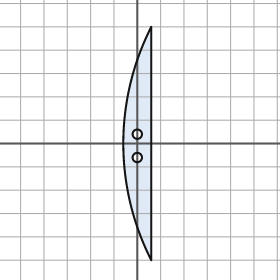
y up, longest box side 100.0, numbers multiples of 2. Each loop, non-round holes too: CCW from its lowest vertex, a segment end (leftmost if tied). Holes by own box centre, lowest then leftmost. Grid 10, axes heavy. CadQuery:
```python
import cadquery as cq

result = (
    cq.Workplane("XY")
    .moveTo(6.0, -50.0)
    .lineTo(6.0, 50.0)
    .threePointArc((-6.0, 0.0), (6.0, -50.0))
    .close()
    .moveTo(0.0, -6.0)
    .circle(2.0)
    .moveTo(0.0, 4.0)
    .circle(2.0)
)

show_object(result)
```